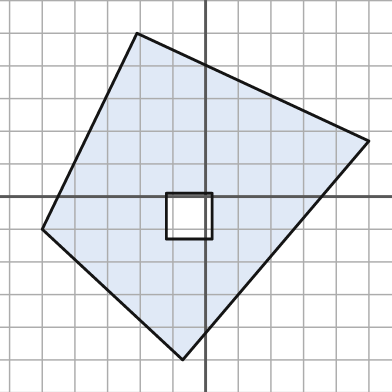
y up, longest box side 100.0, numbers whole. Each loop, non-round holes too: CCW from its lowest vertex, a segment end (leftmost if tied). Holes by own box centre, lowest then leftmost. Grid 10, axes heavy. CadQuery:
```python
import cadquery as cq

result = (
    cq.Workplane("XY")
    .moveTo(-7.0, -50.0)
    .lineTo(50.0, 17.0)
    .lineTo(-21.0, 50.0)
    .lineTo(-50.0, -10.0)
    .close()
    .moveTo(-12.0, -13.0)
    .lineTo(2.0, -13.0)
    .lineTo(2.0, 1.0)
    .lineTo(-12.0, 1.0)
    .close()
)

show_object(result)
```